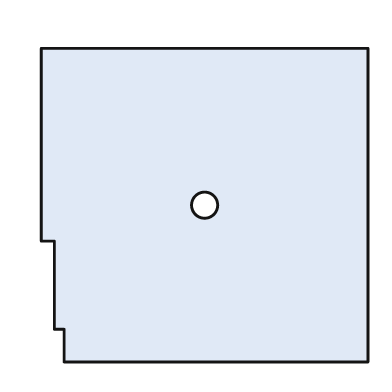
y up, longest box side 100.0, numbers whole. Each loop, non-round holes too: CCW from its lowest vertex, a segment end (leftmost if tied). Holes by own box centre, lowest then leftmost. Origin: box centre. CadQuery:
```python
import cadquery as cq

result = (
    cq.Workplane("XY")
    .moveTo(-43.0, -48.0)
    .lineTo(50.0, -48.0)
    .lineTo(50.0, 48.0)
    .lineTo(-50.0, 48.0)
    .lineTo(-50.0, -11.0)
    .lineTo(-46.0, -11.0)
    .lineTo(-46.0, -38.0)
    .lineTo(-43.0, -38.0)
    .close()
    .moveTo(0.0, 0.0)
    .circle(4.0)
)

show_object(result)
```